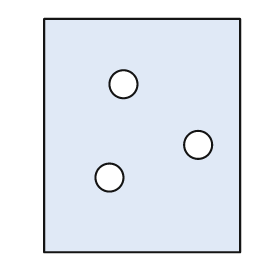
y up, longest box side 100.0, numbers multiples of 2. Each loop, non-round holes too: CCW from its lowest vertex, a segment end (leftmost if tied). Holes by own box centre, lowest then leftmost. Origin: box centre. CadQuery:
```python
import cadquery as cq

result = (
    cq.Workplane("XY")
    .moveTo(-42.0, -50.0)
    .lineTo(42.0, -50.0)
    .lineTo(42.0, 50.0)
    .lineTo(-42.0, 50.0)
    .close()
    .moveTo(-14.0, -18.0)
    .circle(6.0)
    .moveTo(24.0, -4.0)
    .circle(6.0)
    .moveTo(-8.0, 22.0)
    .circle(6.0)
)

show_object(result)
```